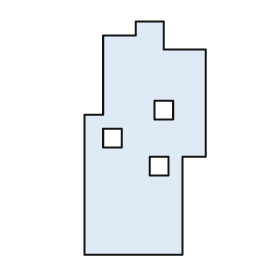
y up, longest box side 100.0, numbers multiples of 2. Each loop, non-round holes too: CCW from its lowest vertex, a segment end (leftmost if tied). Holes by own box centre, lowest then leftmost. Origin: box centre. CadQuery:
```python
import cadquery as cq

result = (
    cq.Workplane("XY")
    .moveTo(-26.0, -50.0)
    .lineTo(16.0, -50.0)
    .lineTo(16.0, -8.0)
    .lineTo(26.0, -8.0)
    .lineTo(26.0, 38.0)
    .lineTo(8.0, 38.0)
    .lineTo(8.0, 50.0)
    .lineTo(-4.0, 50.0)
    .lineTo(-4.0, 44.0)
    .lineTo(-18.0, 44.0)
    .lineTo(-18.0, 10.0)
    .lineTo(-26.0, 10.0)
    .close()
    .moveTo(2.0, -16.0)
    .lineTo(10.0, -16.0)
    .lineTo(10.0, -8.0)
    .lineTo(2.0, -8.0)
    .close()
    .moveTo(-18.0, -4.0)
    .lineTo(-10.0, -4.0)
    .lineTo(-10.0, 4.0)
    .lineTo(-18.0, 4.0)
    .close()
    .moveTo(4.0, 8.0)
    .lineTo(12.0, 8.0)
    .lineTo(12.0, 16.0)
    .lineTo(4.0, 16.0)
    .close()
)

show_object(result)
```